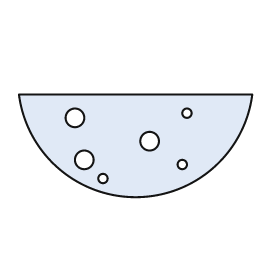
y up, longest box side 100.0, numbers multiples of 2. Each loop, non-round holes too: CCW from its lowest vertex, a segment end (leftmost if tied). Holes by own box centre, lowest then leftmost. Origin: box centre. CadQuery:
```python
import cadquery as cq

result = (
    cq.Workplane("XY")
    .moveTo(-50.0, 22.0)
    .threePointArc((0.0, -22.0), (50.0, 22.0))
    .close()
    .moveTo(-14.0, -14.0)
    .circle(2.0)
    .moveTo(20.0, -8.0)
    .circle(2.0)
    .moveTo(-22.0, -6.0)
    .circle(4.0)
    .moveTo(6.0, 2.0)
    .circle(4.0)
    .moveTo(-26.0, 12.0)
    .circle(4.0)
    .moveTo(22.0, 14.0)
    .circle(2.0)
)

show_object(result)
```